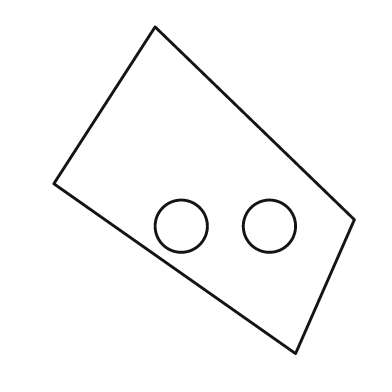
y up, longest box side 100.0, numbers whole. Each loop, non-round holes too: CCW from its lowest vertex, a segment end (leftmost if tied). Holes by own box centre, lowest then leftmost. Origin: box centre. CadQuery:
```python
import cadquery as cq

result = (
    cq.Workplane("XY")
    .moveTo(28.0, -50.0)
    .lineTo(46.0, -9.0)
    .lineTo(-15.0, 50.0)
    .lineTo(-46.0, 2.0)
    .close()
    .moveTo(-7.0, -11.0)
    .circle(8.0)
    .moveTo(20.0, -11.0)
    .circle(8.0)
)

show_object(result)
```